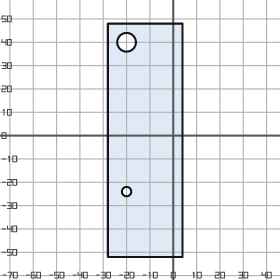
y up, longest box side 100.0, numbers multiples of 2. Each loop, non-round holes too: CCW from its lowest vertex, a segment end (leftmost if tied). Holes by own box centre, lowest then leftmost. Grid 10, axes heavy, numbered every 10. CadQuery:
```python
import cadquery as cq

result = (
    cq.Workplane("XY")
    .moveTo(-28.0, -52.0)
    .lineTo(4.0, -52.0)
    .lineTo(4.0, 48.0)
    .lineTo(-28.0, 48.0)
    .close()
    .moveTo(-20.0, -24.0)
    .circle(2.0)
    .moveTo(-20.0, 40.0)
    .circle(4.0)
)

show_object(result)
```